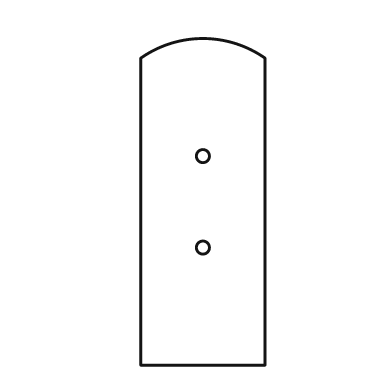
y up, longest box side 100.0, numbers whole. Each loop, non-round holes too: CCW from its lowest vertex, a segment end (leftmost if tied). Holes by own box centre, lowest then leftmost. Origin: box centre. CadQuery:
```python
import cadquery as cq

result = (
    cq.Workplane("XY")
    .moveTo(-19.0, -50.0)
    .lineTo(19.0, -50.0)
    .lineTo(19.0, 44.0)
    .threePointArc((0.0, 50.0), (-19.0, 44.0))
    .close()
    .moveTo(0.0, -14.0)
    .circle(2.0)
    .moveTo(0.0, 14.0)
    .circle(2.0)
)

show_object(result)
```